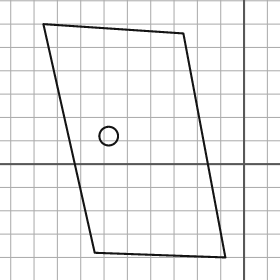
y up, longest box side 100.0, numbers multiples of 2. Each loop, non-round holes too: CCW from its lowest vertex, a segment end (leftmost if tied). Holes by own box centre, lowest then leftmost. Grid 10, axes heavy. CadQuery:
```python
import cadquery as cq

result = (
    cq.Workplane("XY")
    .moveTo(-8.0, -40.0)
    .lineTo(-26.0, 56.0)
    .lineTo(-86.0, 60.0)
    .lineTo(-64.0, -38.0)
    .close()
    .moveTo(-58.0, 12.0)
    .circle(4.0)
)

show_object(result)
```